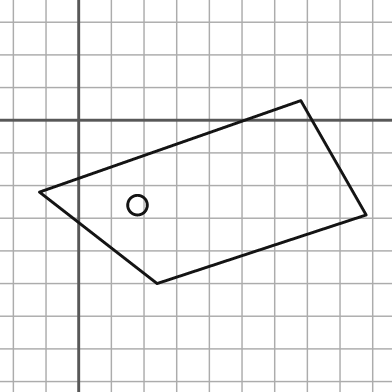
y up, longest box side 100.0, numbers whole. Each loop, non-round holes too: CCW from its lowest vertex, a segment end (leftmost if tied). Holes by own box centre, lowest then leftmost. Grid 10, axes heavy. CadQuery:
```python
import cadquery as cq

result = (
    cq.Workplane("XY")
    .moveTo(24.0, -50.0)
    .lineTo(88.0, -29.0)
    .lineTo(68.0, 6.0)
    .lineTo(-12.0, -22.0)
    .close()
    .moveTo(18.0, -26.0)
    .circle(3.0)
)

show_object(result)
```